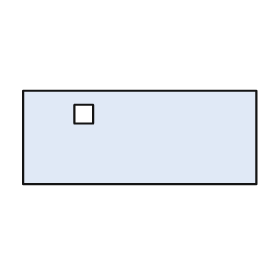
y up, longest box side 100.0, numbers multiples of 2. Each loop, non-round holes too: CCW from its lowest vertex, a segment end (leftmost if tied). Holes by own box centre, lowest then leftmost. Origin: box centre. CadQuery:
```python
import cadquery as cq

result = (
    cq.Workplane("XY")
    .moveTo(-50.0, -20.0)
    .lineTo(50.0, -20.0)
    .lineTo(50.0, 20.0)
    .lineTo(-50.0, 20.0)
    .close()
    .moveTo(-28.0, 6.0)
    .lineTo(-20.0, 6.0)
    .lineTo(-20.0, 14.0)
    .lineTo(-28.0, 14.0)
    .close()
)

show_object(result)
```